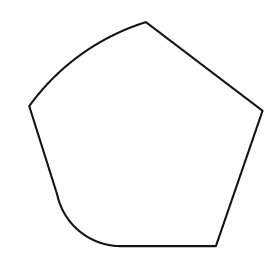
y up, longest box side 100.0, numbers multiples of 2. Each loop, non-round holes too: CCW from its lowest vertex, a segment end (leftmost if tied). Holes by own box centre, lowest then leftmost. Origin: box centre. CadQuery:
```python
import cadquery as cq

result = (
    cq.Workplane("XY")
    .moveTo(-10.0, -48.0)
    .lineTo(30.0, -48.0)
    .lineTo(50.0, 10.0)
    .lineTo(0.0, 48.0)
    .threePointArc((-28.0, 34.0), (-50.0, 12.0))
    .lineTo(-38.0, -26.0)
    .threePointArc((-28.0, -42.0), (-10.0, -48.0))
    .close()
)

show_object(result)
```